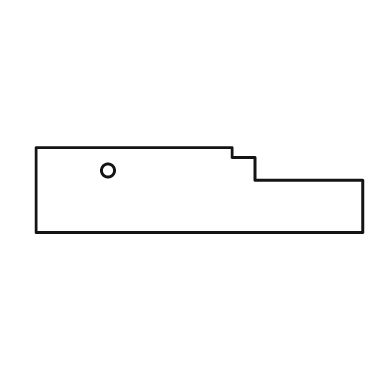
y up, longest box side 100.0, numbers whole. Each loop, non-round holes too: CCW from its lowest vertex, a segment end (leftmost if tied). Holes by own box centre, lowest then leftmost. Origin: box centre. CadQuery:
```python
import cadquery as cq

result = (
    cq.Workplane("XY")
    .moveTo(-50.0, -13.0)
    .lineTo(50.0, -13.0)
    .lineTo(50.0, 3.0)
    .lineTo(17.0, 3.0)
    .lineTo(17.0, 10.0)
    .lineTo(10.0, 10.0)
    .lineTo(10.0, 13.0)
    .lineTo(-50.0, 13.0)
    .close()
    .moveTo(-28.0, 6.0)
    .circle(2.0)
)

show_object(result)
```